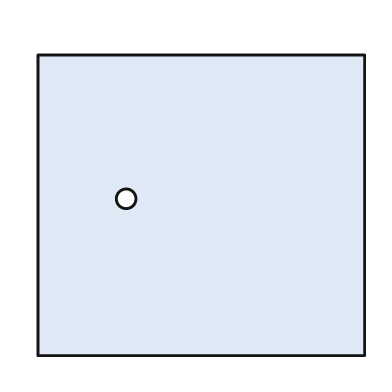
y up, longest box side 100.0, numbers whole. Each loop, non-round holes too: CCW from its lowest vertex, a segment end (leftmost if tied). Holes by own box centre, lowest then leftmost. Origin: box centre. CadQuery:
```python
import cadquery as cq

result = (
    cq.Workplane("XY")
    .moveTo(-50.0, -46.0)
    .lineTo(50.0, -46.0)
    .lineTo(50.0, 46.0)
    .lineTo(-50.0, 46.0)
    .close()
    .moveTo(-23.0, 2.0)
    .circle(3.0)
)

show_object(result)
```